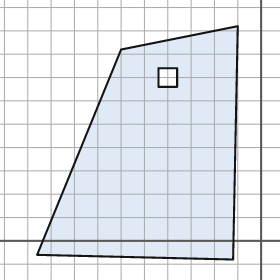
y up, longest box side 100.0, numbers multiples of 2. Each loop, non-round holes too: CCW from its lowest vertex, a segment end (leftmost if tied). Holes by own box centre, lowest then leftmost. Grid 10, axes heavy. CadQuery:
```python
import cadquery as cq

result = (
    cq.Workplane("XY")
    .moveTo(-12.0, -8.0)
    .lineTo(-10.0, 92.0)
    .lineTo(-60.0, 82.0)
    .lineTo(-96.0, -6.0)
    .close()
    .moveTo(-44.0, 66.0)
    .lineTo(-36.0, 66.0)
    .lineTo(-36.0, 74.0)
    .lineTo(-44.0, 74.0)
    .close()
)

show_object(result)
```